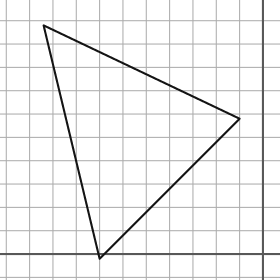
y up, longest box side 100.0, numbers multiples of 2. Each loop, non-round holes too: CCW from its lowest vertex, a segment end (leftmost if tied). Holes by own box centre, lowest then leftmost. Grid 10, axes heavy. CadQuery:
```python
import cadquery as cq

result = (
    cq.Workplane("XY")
    .moveTo(-70.0, -2.0)
    .lineTo(-10.0, 58.0)
    .lineTo(-94.0, 98.0)
    .close()
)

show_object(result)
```